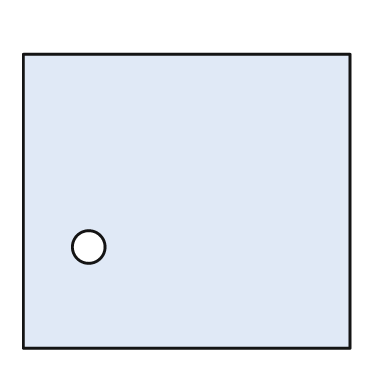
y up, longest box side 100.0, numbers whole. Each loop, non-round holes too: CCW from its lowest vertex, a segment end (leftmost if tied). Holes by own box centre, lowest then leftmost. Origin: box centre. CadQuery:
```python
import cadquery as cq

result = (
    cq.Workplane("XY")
    .moveTo(-50.0, -45.0)
    .lineTo(50.0, -45.0)
    .lineTo(50.0, 45.0)
    .lineTo(-50.0, 45.0)
    .close()
    .moveTo(-30.0, -14.0)
    .circle(5.0)
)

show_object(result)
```